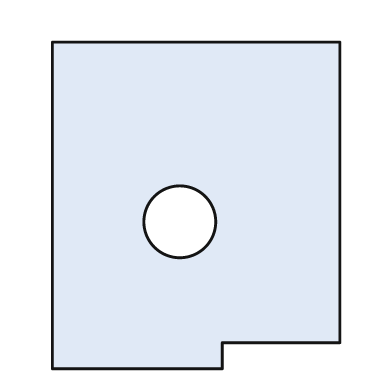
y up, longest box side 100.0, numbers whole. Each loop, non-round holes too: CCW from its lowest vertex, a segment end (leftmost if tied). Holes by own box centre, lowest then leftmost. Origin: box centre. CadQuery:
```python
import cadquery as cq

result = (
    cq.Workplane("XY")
    .moveTo(-44.0, -50.0)
    .lineTo(8.0, -50.0)
    .lineTo(8.0, -42.0)
    .lineTo(44.0, -42.0)
    .lineTo(44.0, 50.0)
    .lineTo(-44.0, 50.0)
    .close()
    .moveTo(-5.0, -5.0)
    .circle(11.0)
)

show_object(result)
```